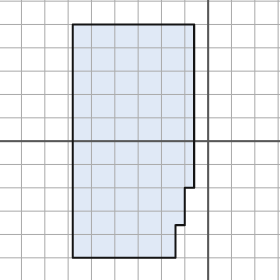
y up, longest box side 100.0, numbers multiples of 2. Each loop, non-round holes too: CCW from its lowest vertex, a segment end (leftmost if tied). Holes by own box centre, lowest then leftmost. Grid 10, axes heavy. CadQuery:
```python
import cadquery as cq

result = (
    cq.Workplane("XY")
    .moveTo(-58.0, -50.0)
    .lineTo(-14.0, -50.0)
    .lineTo(-14.0, -36.0)
    .lineTo(-10.0, -36.0)
    .lineTo(-10.0, -20.0)
    .lineTo(-6.0, -20.0)
    .lineTo(-6.0, 50.0)
    .lineTo(-58.0, 50.0)
    .close()
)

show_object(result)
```